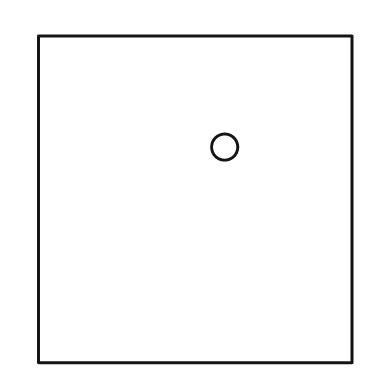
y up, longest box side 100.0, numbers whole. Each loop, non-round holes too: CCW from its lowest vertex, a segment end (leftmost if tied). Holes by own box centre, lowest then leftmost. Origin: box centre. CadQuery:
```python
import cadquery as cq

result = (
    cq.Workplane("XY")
    .moveTo(-48.0, -50.0)
    .lineTo(48.0, -50.0)
    .lineTo(48.0, 50.0)
    .lineTo(-48.0, 50.0)
    .close()
    .moveTo(9.0, 16.0)
    .circle(4.0)
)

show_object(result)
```